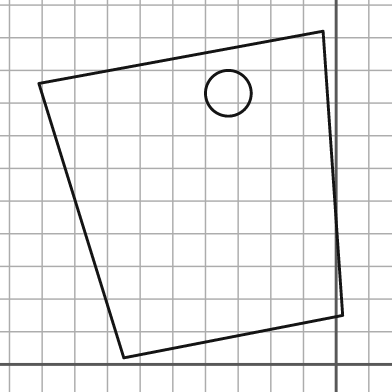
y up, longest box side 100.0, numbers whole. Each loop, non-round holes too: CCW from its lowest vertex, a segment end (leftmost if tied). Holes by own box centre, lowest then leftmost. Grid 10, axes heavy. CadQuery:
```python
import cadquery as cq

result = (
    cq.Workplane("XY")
    .moveTo(-65.0, 2.0)
    .lineTo(2.0, 15.0)
    .lineTo(-4.0, 102.0)
    .lineTo(-91.0, 86.0)
    .close()
    .moveTo(-33.0, 83.0)
    .circle(7.0)
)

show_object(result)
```